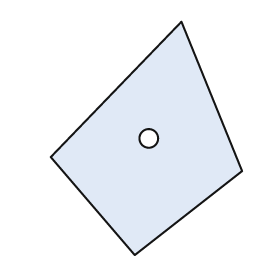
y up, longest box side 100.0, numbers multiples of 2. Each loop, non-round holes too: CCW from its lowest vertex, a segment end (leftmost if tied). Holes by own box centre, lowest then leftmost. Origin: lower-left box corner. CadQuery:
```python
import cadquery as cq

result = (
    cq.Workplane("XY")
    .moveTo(36.0, 0.0)
    .lineTo(82.0, 36.0)
    .lineTo(56.0, 100.0)
    .lineTo(0.0, 42.0)
    .close()
    .moveTo(42.0, 50.0)
    .circle(4.0)
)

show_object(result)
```